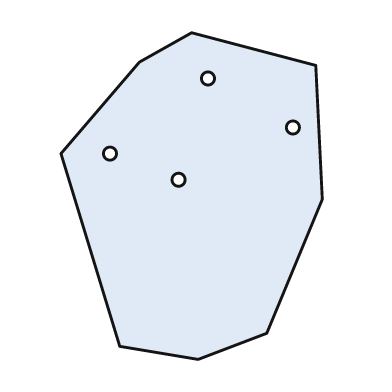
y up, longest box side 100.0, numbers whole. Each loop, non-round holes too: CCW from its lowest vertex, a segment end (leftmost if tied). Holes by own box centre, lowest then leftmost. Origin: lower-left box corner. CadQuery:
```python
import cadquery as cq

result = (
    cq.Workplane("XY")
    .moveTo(42.0, 0.0)
    .lineTo(63.0, 8.0)
    .lineTo(80.0, 49.0)
    .lineTo(78.0, 90.0)
    .lineTo(40.0, 100.0)
    .lineTo(24.0, 91.0)
    .lineTo(0.0, 63.0)
    .lineTo(18.0, 4.0)
    .close()
    .moveTo(36.0, 55.0)
    .circle(2.0)
    .moveTo(15.0, 63.0)
    .circle(2.0)
    .moveTo(71.0, 71.0)
    .circle(2.0)
    .moveTo(45.0, 86.0)
    .circle(2.0)
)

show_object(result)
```